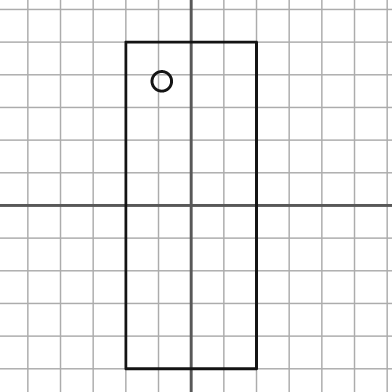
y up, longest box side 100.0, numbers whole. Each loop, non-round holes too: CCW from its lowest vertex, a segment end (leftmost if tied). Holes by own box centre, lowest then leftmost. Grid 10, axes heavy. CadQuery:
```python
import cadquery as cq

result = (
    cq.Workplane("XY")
    .moveTo(-20.0, -50.0)
    .lineTo(20.0, -50.0)
    .lineTo(20.0, 50.0)
    .lineTo(-20.0, 50.0)
    .close()
    .moveTo(-9.0, 38.0)
    .circle(3.0)
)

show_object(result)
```